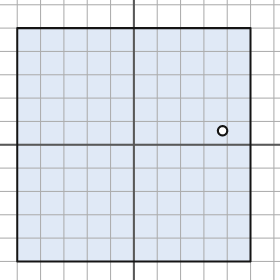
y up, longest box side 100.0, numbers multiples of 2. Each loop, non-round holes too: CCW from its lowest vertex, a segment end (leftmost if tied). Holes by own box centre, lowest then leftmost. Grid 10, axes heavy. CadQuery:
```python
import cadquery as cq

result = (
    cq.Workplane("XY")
    .moveTo(-50.0, -50.0)
    .lineTo(50.0, -50.0)
    .lineTo(50.0, 50.0)
    .lineTo(-50.0, 50.0)
    .close()
    .moveTo(38.0, 6.0)
    .circle(2.0)
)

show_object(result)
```